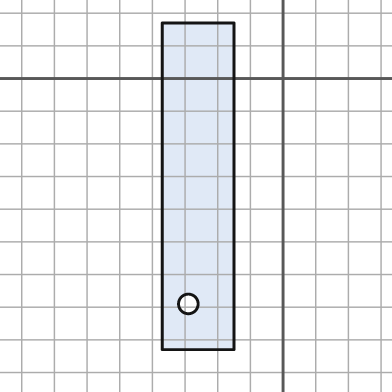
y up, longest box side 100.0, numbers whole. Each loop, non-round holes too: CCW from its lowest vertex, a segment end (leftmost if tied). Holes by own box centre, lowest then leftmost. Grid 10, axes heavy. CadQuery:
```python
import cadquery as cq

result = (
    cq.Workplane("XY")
    .moveTo(-37.0, -83.0)
    .lineTo(-15.0, -83.0)
    .lineTo(-15.0, 17.0)
    .lineTo(-37.0, 17.0)
    .close()
    .moveTo(-29.0, -69.0)
    .circle(3.0)
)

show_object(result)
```